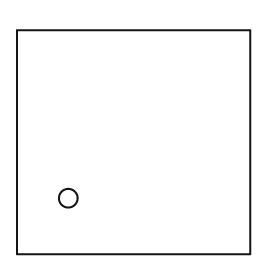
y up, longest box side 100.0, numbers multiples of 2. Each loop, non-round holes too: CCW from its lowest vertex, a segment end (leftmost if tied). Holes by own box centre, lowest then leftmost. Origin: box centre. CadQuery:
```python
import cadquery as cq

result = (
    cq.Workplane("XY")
    .moveTo(-50.0, -48.0)
    .lineTo(50.0, -48.0)
    .lineTo(50.0, 48.0)
    .lineTo(-50.0, 48.0)
    .close()
    .moveTo(-28.0, -24.0)
    .circle(4.0)
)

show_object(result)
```